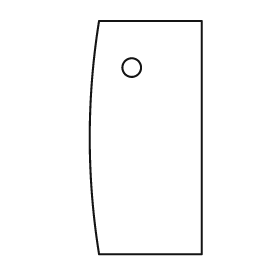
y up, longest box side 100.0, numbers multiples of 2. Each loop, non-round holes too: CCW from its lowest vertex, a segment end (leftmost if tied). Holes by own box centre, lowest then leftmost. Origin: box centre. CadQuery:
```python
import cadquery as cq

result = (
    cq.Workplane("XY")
    .moveTo(-20.0, -50.0)
    .lineTo(24.0, -50.0)
    .lineTo(24.0, 50.0)
    .lineTo(-20.0, 50.0)
    .threePointArc((-24.0, 0.0), (-20.0, -50.0))
    .close()
    .moveTo(-6.0, 30.0)
    .circle(4.0)
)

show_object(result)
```